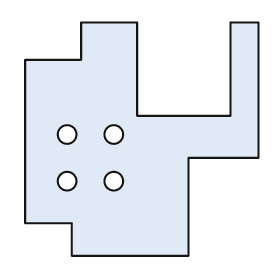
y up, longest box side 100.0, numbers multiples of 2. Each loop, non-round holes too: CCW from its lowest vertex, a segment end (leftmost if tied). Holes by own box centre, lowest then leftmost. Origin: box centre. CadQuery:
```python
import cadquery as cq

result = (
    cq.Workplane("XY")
    .moveTo(-30.0, -50.0)
    .lineTo(20.0, -50.0)
    .lineTo(20.0, -8.0)
    .lineTo(50.0, -8.0)
    .lineTo(50.0, 50.0)
    .lineTo(38.0, 50.0)
    .lineTo(38.0, 10.0)
    .lineTo(-2.0, 10.0)
    .lineTo(-2.0, 50.0)
    .lineTo(-26.0, 50.0)
    .lineTo(-26.0, 34.0)
    .lineTo(-50.0, 34.0)
    .lineTo(-50.0, -36.0)
    .lineTo(-30.0, -36.0)
    .close()
    .moveTo(-32.0, -18.0)
    .circle(4.0)
    .moveTo(-12.0, -18.0)
    .circle(4.0)
    .moveTo(-32.0, 2.0)
    .circle(4.0)
    .moveTo(-12.0, 2.0)
    .circle(4.0)
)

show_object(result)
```